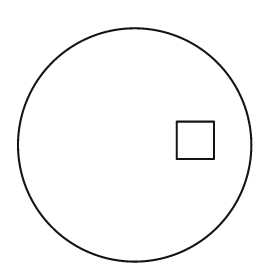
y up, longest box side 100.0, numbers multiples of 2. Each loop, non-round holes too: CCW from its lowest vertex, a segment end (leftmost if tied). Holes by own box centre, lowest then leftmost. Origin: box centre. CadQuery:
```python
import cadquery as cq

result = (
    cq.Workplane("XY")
    .moveTo(0.0, 0.0)
    .circle(50.0)
    .moveTo(18.0, -6.0)
    .lineTo(34.0, -6.0)
    .lineTo(34.0, 10.0)
    .lineTo(18.0, 10.0)
    .close()
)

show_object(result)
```